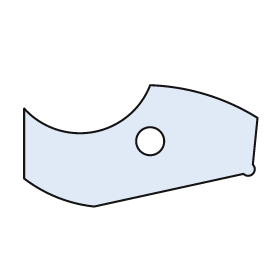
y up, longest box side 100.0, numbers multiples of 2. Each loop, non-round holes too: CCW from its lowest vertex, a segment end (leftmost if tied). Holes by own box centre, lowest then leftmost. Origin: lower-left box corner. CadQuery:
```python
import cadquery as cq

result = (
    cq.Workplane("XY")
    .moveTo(30.0, 0.0)
    .lineTo(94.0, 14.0)
    .threePointArc((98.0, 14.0), (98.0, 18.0))
    .lineTo(100.0, 38.0)
    .threePointArc((78.0, 48.0), (54.0, 52.0))
    .threePointArc((30.0, 32.0), (0.0, 42.0))
    .lineTo(0.0, 12.0)
    .threePointArc((14.0, 4.0), (30.0, 0.0))
    .close()
    .moveTo(54.0, 28.0)
    .circle(6.0)
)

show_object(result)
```